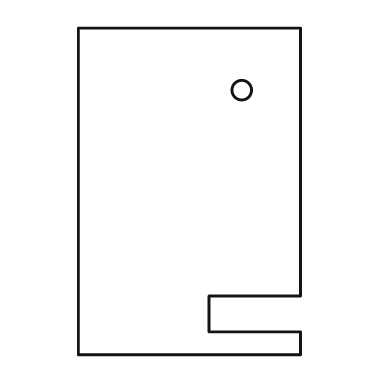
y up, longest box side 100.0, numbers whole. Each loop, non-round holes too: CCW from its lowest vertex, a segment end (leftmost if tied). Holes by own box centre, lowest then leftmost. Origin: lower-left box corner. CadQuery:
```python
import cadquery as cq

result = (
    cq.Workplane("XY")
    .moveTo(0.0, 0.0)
    .lineTo(68.0, 0.0)
    .lineTo(68.0, 7.0)
    .lineTo(40.0, 7.0)
    .lineTo(40.0, 18.0)
    .lineTo(68.0, 18.0)
    .lineTo(68.0, 100.0)
    .lineTo(0.0, 100.0)
    .close()
    .moveTo(50.0, 81.0)
    .circle(3.0)
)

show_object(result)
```